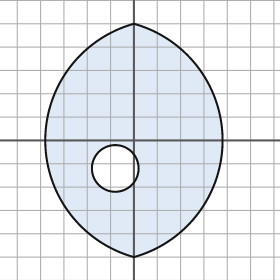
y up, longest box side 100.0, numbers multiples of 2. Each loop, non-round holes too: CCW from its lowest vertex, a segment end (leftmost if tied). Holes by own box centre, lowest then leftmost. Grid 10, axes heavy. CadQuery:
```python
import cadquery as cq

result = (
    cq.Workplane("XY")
    .moveTo(0.0, -50.0)
    .threePointArc((38.0, 0.0), (0.0, 50.0))
    .threePointArc((-38.0, 0.0), (0.0, -50.0))
    .close()
    .moveTo(-8.0, -12.0)
    .circle(10.0)
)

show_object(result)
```